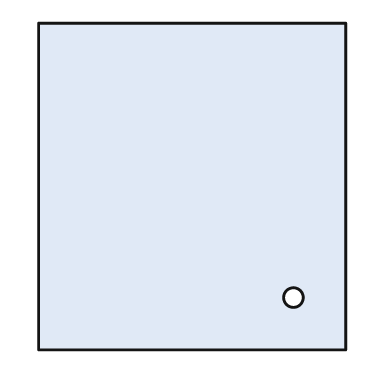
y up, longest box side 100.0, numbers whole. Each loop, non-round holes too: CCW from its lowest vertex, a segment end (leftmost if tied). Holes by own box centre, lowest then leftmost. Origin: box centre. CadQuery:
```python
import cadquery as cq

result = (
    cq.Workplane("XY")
    .moveTo(-47.0, -50.0)
    .lineTo(47.0, -50.0)
    .lineTo(47.0, 50.0)
    .lineTo(-47.0, 50.0)
    .close()
    .moveTo(31.0, -34.0)
    .circle(3.0)
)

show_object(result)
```